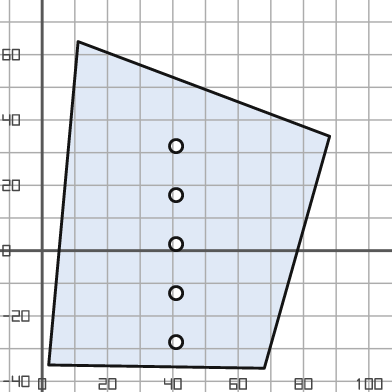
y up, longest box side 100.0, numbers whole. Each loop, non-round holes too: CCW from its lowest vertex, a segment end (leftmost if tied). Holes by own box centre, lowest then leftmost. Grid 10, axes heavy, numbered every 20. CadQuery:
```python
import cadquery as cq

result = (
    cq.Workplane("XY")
    .moveTo(68.0, -36.0)
    .lineTo(88.0, 35.0)
    .lineTo(11.0, 64.0)
    .lineTo(2.0, -35.0)
    .close()
    .moveTo(41.0, -28.0)
    .circle(2.0)
    .moveTo(41.0, -13.0)
    .circle(2.0)
    .moveTo(41.0, 2.0)
    .circle(2.0)
    .moveTo(41.0, 17.0)
    .circle(2.0)
    .moveTo(41.0, 32.0)
    .circle(2.0)
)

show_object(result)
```